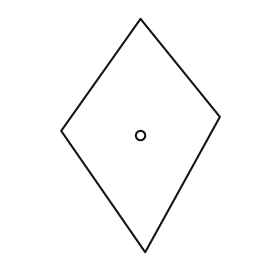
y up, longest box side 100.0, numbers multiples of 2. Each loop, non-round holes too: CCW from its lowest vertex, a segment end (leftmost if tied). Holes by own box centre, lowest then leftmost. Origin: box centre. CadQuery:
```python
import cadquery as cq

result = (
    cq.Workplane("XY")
    .moveTo(2.0, -50.0)
    .lineTo(34.0, 8.0)
    .lineTo(0.0, 50.0)
    .lineTo(-34.0, 2.0)
    .close()
    .moveTo(0.0, 0.0)
    .circle(2.0)
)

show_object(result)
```